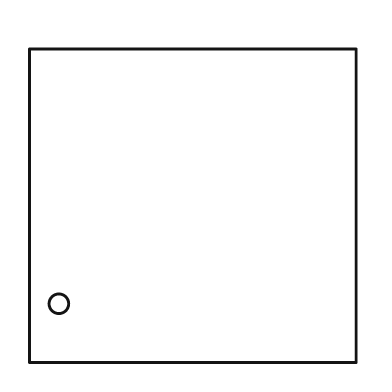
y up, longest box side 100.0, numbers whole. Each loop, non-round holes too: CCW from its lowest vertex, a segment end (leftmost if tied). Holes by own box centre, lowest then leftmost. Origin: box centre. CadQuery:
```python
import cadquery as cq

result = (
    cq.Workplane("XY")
    .moveTo(-50.0, -48.0)
    .lineTo(50.0, -48.0)
    .lineTo(50.0, 48.0)
    .lineTo(-50.0, 48.0)
    .close()
    .moveTo(-41.0, -30.0)
    .circle(3.0)
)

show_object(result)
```